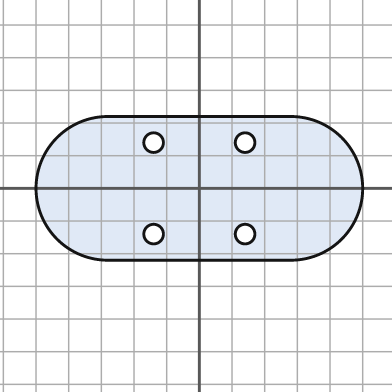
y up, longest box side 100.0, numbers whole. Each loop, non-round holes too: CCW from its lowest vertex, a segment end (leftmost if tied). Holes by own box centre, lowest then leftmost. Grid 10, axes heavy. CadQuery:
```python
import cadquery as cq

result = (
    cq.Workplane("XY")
    .moveTo(-28.0, -22.0)
    .lineTo(28.0, -22.0)
    .threePointArc((50.0, 0.0), (28.0, 22.0))
    .lineTo(-28.0, 22.0)
    .threePointArc((-50.0, 0.0), (-28.0, -22.0))
    .close()
    .moveTo(-14.0, -14.0)
    .circle(3.0)
    .moveTo(14.0, -14.0)
    .circle(3.0)
    .moveTo(-14.0, 14.0)
    .circle(3.0)
    .moveTo(14.0, 14.0)
    .circle(3.0)
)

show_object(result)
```